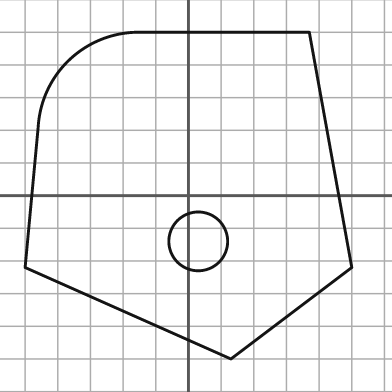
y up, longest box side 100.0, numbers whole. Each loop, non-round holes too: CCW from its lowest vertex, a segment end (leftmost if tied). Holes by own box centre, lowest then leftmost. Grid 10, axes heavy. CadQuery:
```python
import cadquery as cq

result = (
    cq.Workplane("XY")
    .moveTo(13.0, -50.0)
    .lineTo(50.0, -22.0)
    .lineTo(37.0, 50.0)
    .lineTo(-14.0, 50.0)
    .threePointArc((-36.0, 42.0), (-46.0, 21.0))
    .lineTo(-50.0, -22.0)
    .close()
    .moveTo(3.0, -14.0)
    .circle(9.0)
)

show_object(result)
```